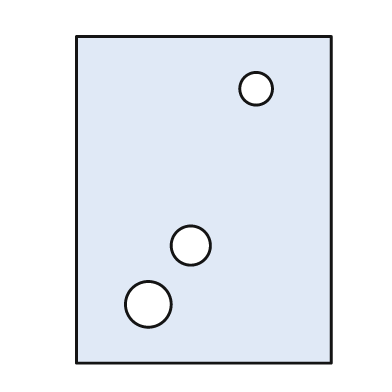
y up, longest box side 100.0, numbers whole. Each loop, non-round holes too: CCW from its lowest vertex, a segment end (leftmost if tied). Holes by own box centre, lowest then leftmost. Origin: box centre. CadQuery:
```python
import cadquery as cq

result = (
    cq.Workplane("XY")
    .moveTo(-39.0, -50.0)
    .lineTo(39.0, -50.0)
    .lineTo(39.0, 50.0)
    .lineTo(-39.0, 50.0)
    .close()
    .moveTo(-17.0, -32.0)
    .circle(7.0)
    .moveTo(-4.0, -14.0)
    .circle(6.0)
    .moveTo(16.0, 34.0)
    .circle(5.0)
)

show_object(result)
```